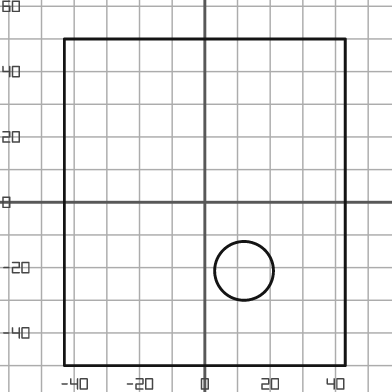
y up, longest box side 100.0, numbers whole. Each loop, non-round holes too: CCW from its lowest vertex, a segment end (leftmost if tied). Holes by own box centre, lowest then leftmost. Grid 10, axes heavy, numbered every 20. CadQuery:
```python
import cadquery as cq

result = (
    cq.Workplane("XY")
    .moveTo(-43.0, -50.0)
    .lineTo(43.0, -50.0)
    .lineTo(43.0, 50.0)
    .lineTo(-43.0, 50.0)
    .close()
    .moveTo(12.0, -21.0)
    .circle(9.0)
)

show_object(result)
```